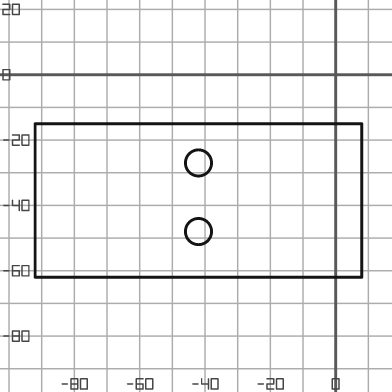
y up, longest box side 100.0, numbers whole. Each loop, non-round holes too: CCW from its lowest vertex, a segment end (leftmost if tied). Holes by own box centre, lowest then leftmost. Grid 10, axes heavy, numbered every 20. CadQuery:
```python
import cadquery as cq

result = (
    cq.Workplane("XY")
    .moveTo(-92.0, -62.0)
    .lineTo(8.0, -62.0)
    .lineTo(8.0, -15.0)
    .lineTo(-92.0, -15.0)
    .close()
    .moveTo(-42.0, -48.0)
    .circle(4.0)
    .moveTo(-42.0, -27.0)
    .circle(4.0)
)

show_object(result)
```